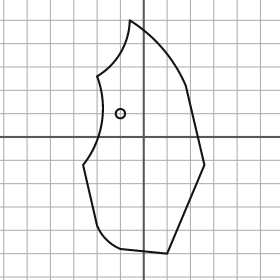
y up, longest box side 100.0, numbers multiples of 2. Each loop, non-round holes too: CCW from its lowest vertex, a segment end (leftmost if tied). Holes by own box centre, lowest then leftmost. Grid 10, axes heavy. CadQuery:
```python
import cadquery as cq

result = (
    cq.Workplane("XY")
    .moveTo(10.0, -50.0)
    .lineTo(26.0, -12.0)
    .lineTo(18.0, 22.0)
    .threePointArc((8.0, 38.0), (-6.0, 50.0))
    .threePointArc((-10.0, 36.0), (-20.0, 26.0))
    .threePointArc((-18.0, 6.0), (-26.0, -12.0))
    .lineTo(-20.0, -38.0)
    .threePointArc((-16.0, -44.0), (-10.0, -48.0))
    .close()
    .moveTo(-10.0, 10.0)
    .circle(2.0)
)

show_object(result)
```